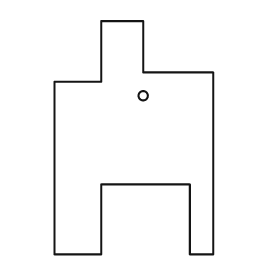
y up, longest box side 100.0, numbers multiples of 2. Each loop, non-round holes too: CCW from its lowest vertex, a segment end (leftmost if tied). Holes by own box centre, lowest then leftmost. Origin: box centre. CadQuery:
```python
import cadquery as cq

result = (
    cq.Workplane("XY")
    .moveTo(-34.0, -50.0)
    .lineTo(-14.0, -50.0)
    .lineTo(-14.0, -20.0)
    .lineTo(24.0, -20.0)
    .lineTo(24.0, -50.0)
    .lineTo(34.0, -50.0)
    .lineTo(34.0, 28.0)
    .lineTo(4.0, 28.0)
    .lineTo(4.0, 50.0)
    .lineTo(-14.0, 50.0)
    .lineTo(-14.0, 24.0)
    .lineTo(-34.0, 24.0)
    .close()
    .moveTo(4.0, 18.0)
    .circle(2.0)
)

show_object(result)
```